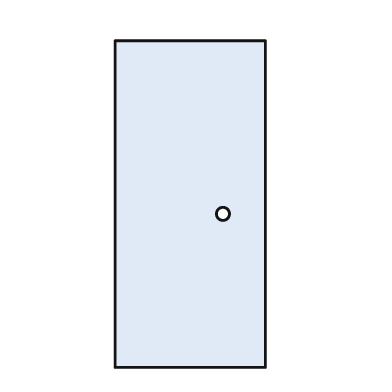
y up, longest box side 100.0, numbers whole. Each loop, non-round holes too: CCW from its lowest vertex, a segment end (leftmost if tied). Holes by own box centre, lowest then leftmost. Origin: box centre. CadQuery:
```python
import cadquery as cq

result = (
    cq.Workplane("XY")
    .moveTo(-23.0, -50.0)
    .lineTo(23.0, -50.0)
    .lineTo(23.0, 50.0)
    .lineTo(-23.0, 50.0)
    .close()
    .moveTo(10.0, -3.0)
    .circle(2.0)
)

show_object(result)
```